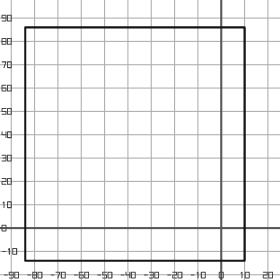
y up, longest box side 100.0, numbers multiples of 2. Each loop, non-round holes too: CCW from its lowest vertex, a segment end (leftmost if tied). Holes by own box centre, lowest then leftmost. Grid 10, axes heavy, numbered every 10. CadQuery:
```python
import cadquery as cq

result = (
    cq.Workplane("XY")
    .moveTo(-84.0, -14.0)
    .lineTo(10.0, -14.0)
    .lineTo(10.0, 86.0)
    .lineTo(-84.0, 86.0)
    .close()
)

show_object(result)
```